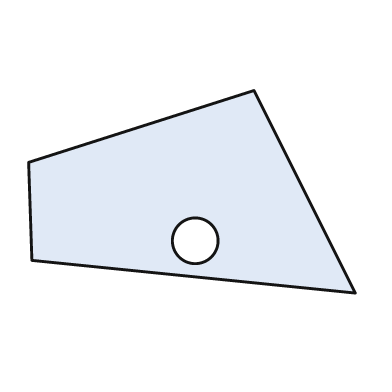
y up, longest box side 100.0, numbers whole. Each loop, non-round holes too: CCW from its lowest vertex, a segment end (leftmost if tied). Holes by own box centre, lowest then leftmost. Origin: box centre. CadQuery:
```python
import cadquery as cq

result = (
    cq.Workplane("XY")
    .moveTo(50.0, -31.0)
    .lineTo(19.0, 31.0)
    .lineTo(-50.0, 9.0)
    .lineTo(-49.0, -21.0)
    .close()
    .moveTo(1.0, -15.0)
    .circle(7.0)
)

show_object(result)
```